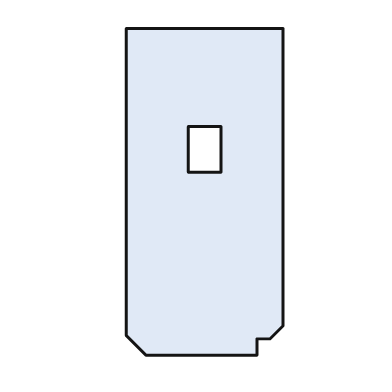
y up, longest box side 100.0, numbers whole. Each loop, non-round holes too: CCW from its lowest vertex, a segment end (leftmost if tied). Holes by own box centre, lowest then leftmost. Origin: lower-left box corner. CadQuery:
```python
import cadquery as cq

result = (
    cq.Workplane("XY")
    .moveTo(6.0, 0.0)
    .lineTo(40.0, 0.0)
    .lineTo(40.0, 5.0)
    .lineTo(44.0, 5.0)
    .lineTo(48.0, 9.0)
    .lineTo(48.0, 100.0)
    .lineTo(0.0, 100.0)
    .lineTo(0.0, 6.0)
    .close()
    .moveTo(19.0, 56.0)
    .lineTo(29.0, 56.0)
    .lineTo(29.0, 70.0)
    .lineTo(19.0, 70.0)
    .close()
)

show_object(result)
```